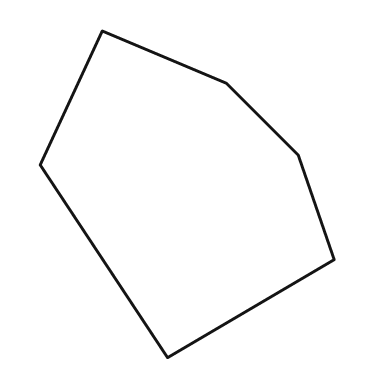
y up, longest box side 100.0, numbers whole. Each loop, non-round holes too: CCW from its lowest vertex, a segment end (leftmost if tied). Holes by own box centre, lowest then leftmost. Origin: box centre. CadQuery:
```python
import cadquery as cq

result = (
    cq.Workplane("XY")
    .moveTo(-6.0, -50.0)
    .lineTo(45.0, -20.0)
    .lineTo(34.0, 12.0)
    .lineTo(12.0, 34.0)
    .lineTo(-26.0, 50.0)
    .lineTo(-45.0, 9.0)
    .close()
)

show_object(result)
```